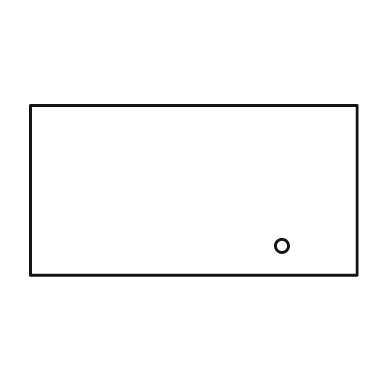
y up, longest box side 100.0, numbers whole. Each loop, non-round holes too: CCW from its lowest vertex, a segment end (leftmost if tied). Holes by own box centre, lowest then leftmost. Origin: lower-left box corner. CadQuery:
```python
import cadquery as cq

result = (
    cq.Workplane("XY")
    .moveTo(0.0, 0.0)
    .lineTo(100.0, 0.0)
    .lineTo(100.0, 52.0)
    .lineTo(0.0, 52.0)
    .close()
    .moveTo(77.0, 9.0)
    .circle(2.0)
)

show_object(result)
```